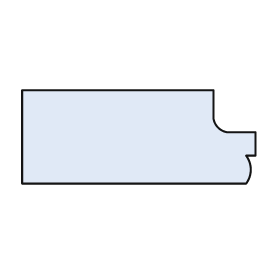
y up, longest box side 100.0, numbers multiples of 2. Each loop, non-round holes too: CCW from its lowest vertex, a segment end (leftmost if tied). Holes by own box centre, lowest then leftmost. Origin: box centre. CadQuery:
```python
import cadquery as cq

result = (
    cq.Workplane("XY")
    .moveTo(-50.0, -20.0)
    .lineTo(46.0, -20.0)
    .threePointArc((48.0, -14.0), (46.0, -8.0))
    .lineTo(50.0, -8.0)
    .lineTo(50.0, 2.0)
    .lineTo(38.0, 2.0)
    .threePointArc((34.0, 4.0), (32.0, 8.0))
    .lineTo(32.0, 20.0)
    .lineTo(-50.0, 20.0)
    .close()
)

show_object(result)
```